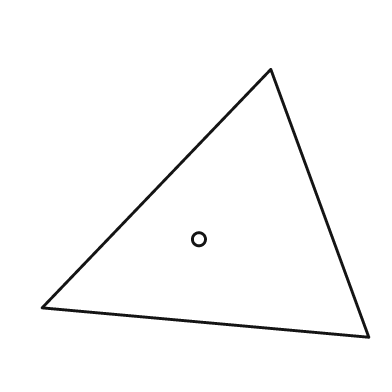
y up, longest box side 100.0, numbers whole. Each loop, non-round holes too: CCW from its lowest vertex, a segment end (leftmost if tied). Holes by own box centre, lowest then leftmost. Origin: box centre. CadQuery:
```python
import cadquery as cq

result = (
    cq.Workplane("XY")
    .moveTo(50.0, -41.0)
    .lineTo(20.0, 41.0)
    .lineTo(-50.0, -32.0)
    .close()
    .moveTo(-2.0, -11.0)
    .circle(2.0)
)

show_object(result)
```